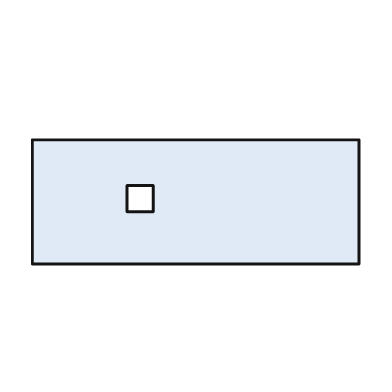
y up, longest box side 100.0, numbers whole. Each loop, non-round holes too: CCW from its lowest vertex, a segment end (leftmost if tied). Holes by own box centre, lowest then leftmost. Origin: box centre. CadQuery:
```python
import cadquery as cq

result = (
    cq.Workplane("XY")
    .moveTo(-50.0, -19.0)
    .lineTo(50.0, -19.0)
    .lineTo(50.0, 19.0)
    .lineTo(-50.0, 19.0)
    .close()
    .moveTo(-21.0, -3.0)
    .lineTo(-13.0, -3.0)
    .lineTo(-13.0, 5.0)
    .lineTo(-21.0, 5.0)
    .close()
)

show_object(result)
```